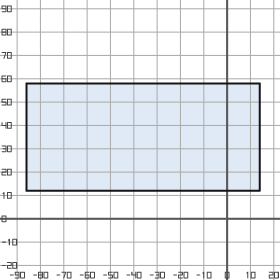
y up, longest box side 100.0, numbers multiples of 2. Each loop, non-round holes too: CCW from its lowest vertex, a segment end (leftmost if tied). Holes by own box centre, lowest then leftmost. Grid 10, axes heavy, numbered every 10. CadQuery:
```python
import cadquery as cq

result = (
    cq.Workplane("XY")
    .moveTo(-86.0, 12.0)
    .lineTo(14.0, 12.0)
    .lineTo(14.0, 58.0)
    .lineTo(-86.0, 58.0)
    .close()
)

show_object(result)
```